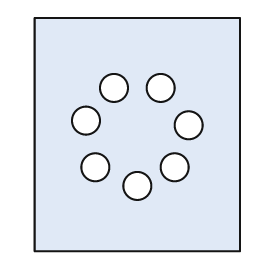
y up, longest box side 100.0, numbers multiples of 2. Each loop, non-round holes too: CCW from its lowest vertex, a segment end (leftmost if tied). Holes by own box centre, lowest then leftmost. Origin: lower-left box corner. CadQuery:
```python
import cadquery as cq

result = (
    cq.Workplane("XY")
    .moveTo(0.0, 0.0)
    .lineTo(88.0, 0.0)
    .lineTo(88.0, 100.0)
    .lineTo(0.0, 100.0)
    .close()
    .moveTo(44.0, 28.0)
    .circle(6.0)
    .moveTo(26.0, 36.0)
    .circle(6.0)
    .moveTo(60.0, 36.0)
    .circle(6.0)
    .moveTo(66.0, 54.0)
    .circle(6.0)
    .moveTo(22.0, 56.0)
    .circle(6.0)
    .moveTo(34.0, 70.0)
    .circle(6.0)
    .moveTo(54.0, 70.0)
    .circle(6.0)
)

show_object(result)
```